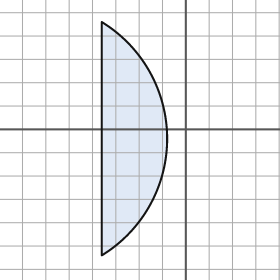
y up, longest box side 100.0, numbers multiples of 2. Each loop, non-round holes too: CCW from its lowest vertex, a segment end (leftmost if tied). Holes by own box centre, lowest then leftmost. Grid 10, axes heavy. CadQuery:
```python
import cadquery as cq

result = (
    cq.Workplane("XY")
    .moveTo(-36.0, -54.0)
    .threePointArc((-8.0, -4.0), (-36.0, 46.0))
    .close()
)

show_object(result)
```